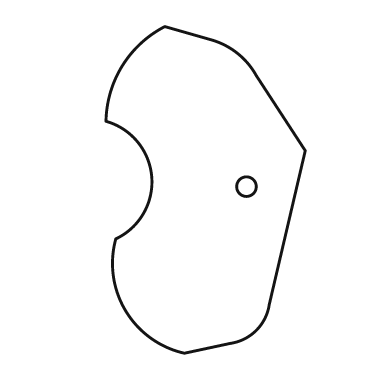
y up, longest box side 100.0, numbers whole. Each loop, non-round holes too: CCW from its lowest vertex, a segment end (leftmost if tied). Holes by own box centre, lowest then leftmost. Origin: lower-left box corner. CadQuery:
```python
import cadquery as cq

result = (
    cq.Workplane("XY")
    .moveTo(24.0, 0.0)
    .lineTo(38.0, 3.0)
    .threePointArc((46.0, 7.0), (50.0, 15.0))
    .lineTo(61.0, 62.0)
    .lineTo(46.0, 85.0)
    .threePointArc((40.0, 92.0), (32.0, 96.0))
    .lineTo(18.0, 100.0)
    .threePointArc((5.0, 88.0), (0.0, 71.0))
    .threePointArc((14.0, 54.0), (3.0, 35.0))
    .threePointArc((6.0, 13.0), (24.0, 0.0))
    .close()
    .moveTo(43.0, 51.0)
    .circle(3.0)
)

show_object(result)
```